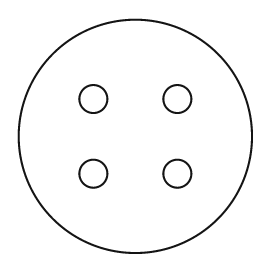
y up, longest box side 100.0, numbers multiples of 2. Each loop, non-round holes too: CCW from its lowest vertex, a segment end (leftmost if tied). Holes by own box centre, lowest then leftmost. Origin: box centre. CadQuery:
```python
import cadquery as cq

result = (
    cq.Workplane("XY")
    .moveTo(0.0, 0.0)
    .circle(50.0)
    .moveTo(-18.0, -16.0)
    .circle(6.0)
    .moveTo(18.0, -16.0)
    .circle(6.0)
    .moveTo(-18.0, 16.0)
    .circle(6.0)
    .moveTo(18.0, 16.0)
    .circle(6.0)
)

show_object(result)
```